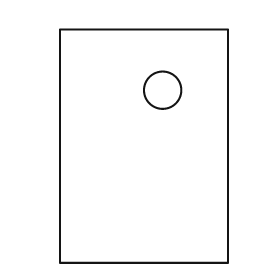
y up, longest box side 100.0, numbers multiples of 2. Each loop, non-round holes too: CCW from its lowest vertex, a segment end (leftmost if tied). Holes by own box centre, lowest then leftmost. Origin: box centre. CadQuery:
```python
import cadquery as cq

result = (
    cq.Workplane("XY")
    .moveTo(-36.0, -50.0)
    .lineTo(36.0, -50.0)
    .lineTo(36.0, 50.0)
    .lineTo(-36.0, 50.0)
    .close()
    .moveTo(8.0, 24.0)
    .circle(8.0)
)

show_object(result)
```